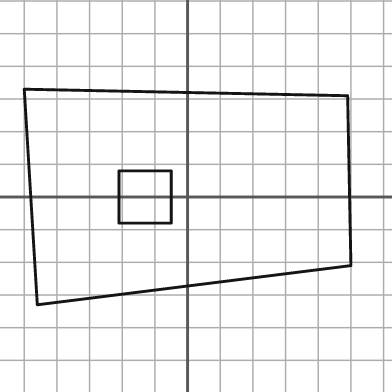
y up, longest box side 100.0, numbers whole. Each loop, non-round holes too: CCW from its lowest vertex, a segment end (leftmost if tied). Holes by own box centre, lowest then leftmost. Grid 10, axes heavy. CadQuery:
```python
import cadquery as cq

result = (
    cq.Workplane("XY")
    .moveTo(-46.0, -33.0)
    .lineTo(50.0, -21.0)
    .lineTo(49.0, 31.0)
    .lineTo(-50.0, 33.0)
    .close()
    .moveTo(-21.0, -8.0)
    .lineTo(-5.0, -8.0)
    .lineTo(-5.0, 8.0)
    .lineTo(-21.0, 8.0)
    .close()
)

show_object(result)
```